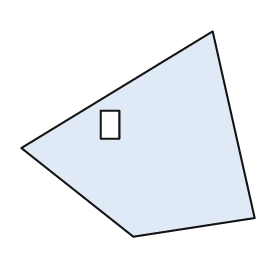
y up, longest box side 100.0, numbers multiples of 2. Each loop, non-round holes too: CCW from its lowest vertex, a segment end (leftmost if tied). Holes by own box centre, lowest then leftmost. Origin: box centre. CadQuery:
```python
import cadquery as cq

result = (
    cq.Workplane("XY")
    .moveTo(-2.0, -44.0)
    .lineTo(50.0, -36.0)
    .lineTo(32.0, 44.0)
    .lineTo(-50.0, -6.0)
    .close()
    .moveTo(-16.0, -2.0)
    .lineTo(-8.0, -2.0)
    .lineTo(-8.0, 10.0)
    .lineTo(-16.0, 10.0)
    .close()
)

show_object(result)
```